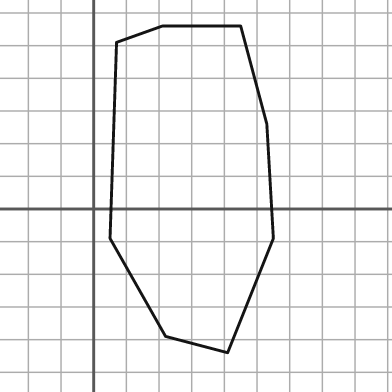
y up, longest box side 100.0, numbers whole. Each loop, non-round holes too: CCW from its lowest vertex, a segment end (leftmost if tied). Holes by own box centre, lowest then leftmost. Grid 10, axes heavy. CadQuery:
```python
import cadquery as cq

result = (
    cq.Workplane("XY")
    .moveTo(41.0, -44.0)
    .lineTo(55.0, -9.0)
    .lineTo(53.0, 26.0)
    .lineTo(45.0, 56.0)
    .lineTo(21.0, 56.0)
    .lineTo(7.0, 51.0)
    .lineTo(5.0, -9.0)
    .lineTo(22.0, -39.0)
    .close()
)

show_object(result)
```